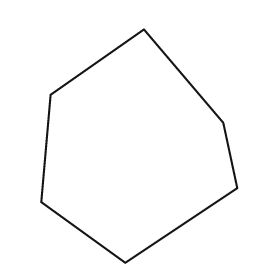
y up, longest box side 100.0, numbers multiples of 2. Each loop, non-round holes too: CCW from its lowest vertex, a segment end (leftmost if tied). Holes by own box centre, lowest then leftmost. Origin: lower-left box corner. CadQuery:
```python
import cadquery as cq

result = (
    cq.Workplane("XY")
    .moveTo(36.0, 0.0)
    .lineTo(84.0, 32.0)
    .lineTo(78.0, 60.0)
    .lineTo(44.0, 100.0)
    .lineTo(4.0, 72.0)
    .lineTo(0.0, 26.0)
    .close()
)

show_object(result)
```